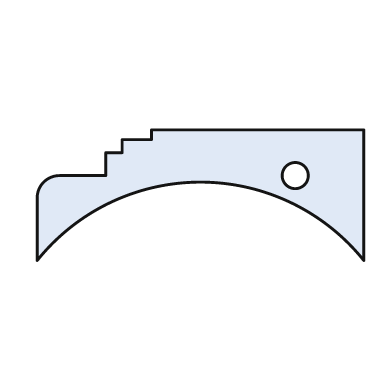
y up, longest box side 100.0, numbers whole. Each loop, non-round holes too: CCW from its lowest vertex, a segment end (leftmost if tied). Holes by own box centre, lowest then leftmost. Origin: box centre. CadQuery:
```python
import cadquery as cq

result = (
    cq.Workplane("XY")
    .moveTo(-50.0, -20.0)
    .threePointArc((0.0, 4.0), (50.0, -20.0))
    .lineTo(50.0, 20.0)
    .lineTo(-15.0, 20.0)
    .lineTo(-15.0, 17.0)
    .lineTo(-24.0, 17.0)
    .lineTo(-24.0, 13.0)
    .lineTo(-29.0, 13.0)
    .lineTo(-29.0, 6.0)
    .lineTo(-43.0, 6.0)
    .threePointArc((-48.0, 4.0), (-50.0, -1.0))
    .close()
    .moveTo(29.0, 6.0)
    .circle(4.0)
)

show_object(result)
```